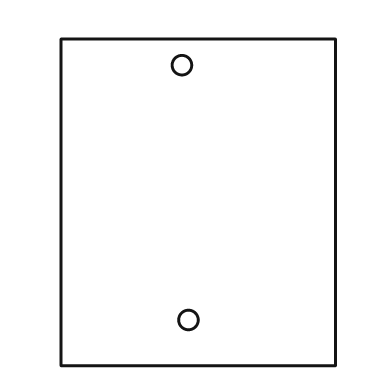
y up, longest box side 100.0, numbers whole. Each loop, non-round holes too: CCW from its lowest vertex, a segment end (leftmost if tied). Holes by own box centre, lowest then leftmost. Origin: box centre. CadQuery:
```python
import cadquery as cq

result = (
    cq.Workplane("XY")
    .moveTo(-42.0, -50.0)
    .lineTo(42.0, -50.0)
    .lineTo(42.0, 50.0)
    .lineTo(-42.0, 50.0)
    .close()
    .moveTo(-3.0, -36.0)
    .circle(3.0)
    .moveTo(-5.0, 42.0)
    .circle(3.0)
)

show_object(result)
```